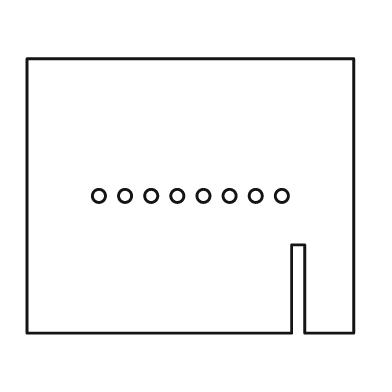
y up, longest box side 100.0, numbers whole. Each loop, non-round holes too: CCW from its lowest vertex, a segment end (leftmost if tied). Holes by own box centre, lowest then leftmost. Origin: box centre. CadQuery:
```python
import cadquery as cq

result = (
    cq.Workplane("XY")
    .moveTo(-50.0, -42.0)
    .lineTo(31.0, -42.0)
    .lineTo(31.0, -15.0)
    .lineTo(35.0, -15.0)
    .lineTo(35.0, -42.0)
    .lineTo(50.0, -42.0)
    .lineTo(50.0, 42.0)
    .lineTo(-50.0, 42.0)
    .close()
    .moveTo(-28.0, 0.0)
    .circle(2.0)
    .moveTo(-20.0, 0.0)
    .circle(2.0)
    .moveTo(-12.0, 0.0)
    .circle(2.0)
    .moveTo(-4.0, 0.0)
    .circle(2.0)
    .moveTo(4.0, 0.0)
    .circle(2.0)
    .moveTo(12.0, 0.0)
    .circle(2.0)
    .moveTo(20.0, 0.0)
    .circle(2.0)
    .moveTo(28.0, 0.0)
    .circle(2.0)
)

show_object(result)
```